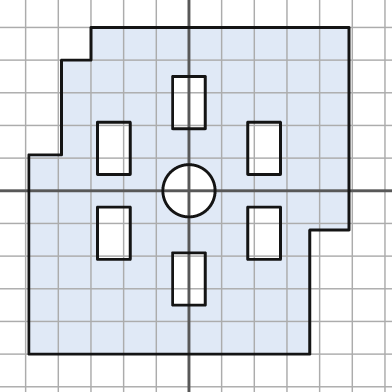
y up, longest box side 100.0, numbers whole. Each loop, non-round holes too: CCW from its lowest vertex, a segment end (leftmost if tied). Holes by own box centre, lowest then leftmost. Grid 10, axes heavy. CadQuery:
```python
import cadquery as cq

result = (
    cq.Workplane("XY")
    .moveTo(-49.0, -50.0)
    .lineTo(37.0, -50.0)
    .lineTo(37.0, -12.0)
    .lineTo(49.0, -12.0)
    .lineTo(49.0, 50.0)
    .lineTo(-30.0, 50.0)
    .lineTo(-30.0, 40.0)
    .lineTo(-39.0, 40.0)
    .lineTo(-39.0, 11.0)
    .lineTo(-49.0, 11.0)
    .close()
    .moveTo(-5.0, -35.0)
    .lineTo(5.0, -35.0)
    .lineTo(5.0, -19.0)
    .lineTo(-5.0, -19.0)
    .close()
    .moveTo(-28.0, -21.0)
    .lineTo(-18.0, -21.0)
    .lineTo(-18.0, -5.0)
    .lineTo(-28.0, -5.0)
    .close()
    .moveTo(18.0, -21.0)
    .lineTo(28.0, -21.0)
    .lineTo(28.0, -5.0)
    .lineTo(18.0, -5.0)
    .close()
    .moveTo(0.0, 0.0)
    .circle(8.0)
    .moveTo(-28.0, 5.0)
    .lineTo(-18.0, 5.0)
    .lineTo(-18.0, 21.0)
    .lineTo(-28.0, 21.0)
    .close()
    .moveTo(18.0, 5.0)
    .lineTo(28.0, 5.0)
    .lineTo(28.0, 21.0)
    .lineTo(18.0, 21.0)
    .close()
    .moveTo(-5.0, 19.0)
    .lineTo(5.0, 19.0)
    .lineTo(5.0, 35.0)
    .lineTo(-5.0, 35.0)
    .close()
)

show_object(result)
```